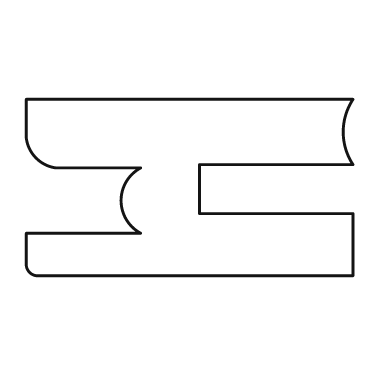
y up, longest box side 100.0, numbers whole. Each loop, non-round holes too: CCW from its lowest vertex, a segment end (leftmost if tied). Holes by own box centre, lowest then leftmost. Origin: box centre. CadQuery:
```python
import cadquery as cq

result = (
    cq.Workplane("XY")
    .moveTo(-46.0, -27.0)
    .lineTo(50.0, -27.0)
    .lineTo(50.0, -8.0)
    .lineTo(3.0, -8.0)
    .lineTo(3.0, 7.0)
    .lineTo(50.0, 7.0)
    .threePointArc((47.0, 17.0), (50.0, 27.0))
    .lineTo(-50.0, 27.0)
    .lineTo(-50.0, 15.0)
    .threePointArc((-47.0, 9.0), (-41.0, 6.0))
    .lineTo(-15.0, 6.0)
    .threePointArc((-21.0, -4.0), (-15.0, -14.0))
    .lineTo(-50.0, -14.0)
    .lineTo(-50.0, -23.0)
    .threePointArc((-49.0, -26.0), (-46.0, -27.0))
    .close()
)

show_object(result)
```